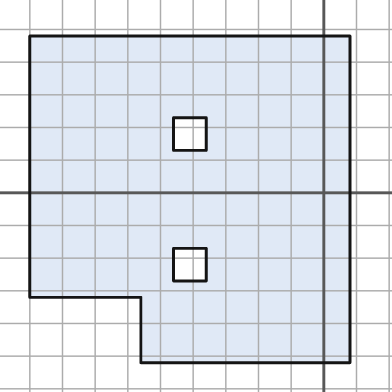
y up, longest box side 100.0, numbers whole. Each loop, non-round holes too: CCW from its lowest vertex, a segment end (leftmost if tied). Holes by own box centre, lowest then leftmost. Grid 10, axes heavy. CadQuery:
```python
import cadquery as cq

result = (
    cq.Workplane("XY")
    .moveTo(-56.0, -52.0)
    .lineTo(8.0, -52.0)
    .lineTo(8.0, 48.0)
    .lineTo(-90.0, 48.0)
    .lineTo(-90.0, -32.0)
    .lineTo(-56.0, -32.0)
    .close()
    .moveTo(-46.0, -27.0)
    .lineTo(-36.0, -27.0)
    .lineTo(-36.0, -17.0)
    .lineTo(-46.0, -17.0)
    .close()
    .moveTo(-46.0, 13.0)
    .lineTo(-36.0, 13.0)
    .lineTo(-36.0, 23.0)
    .lineTo(-46.0, 23.0)
    .close()
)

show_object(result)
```